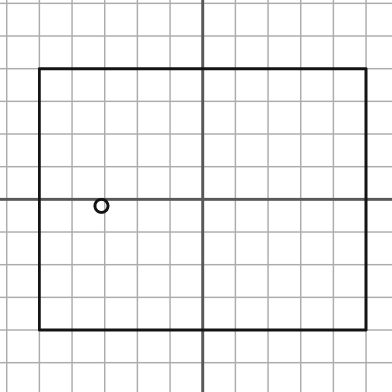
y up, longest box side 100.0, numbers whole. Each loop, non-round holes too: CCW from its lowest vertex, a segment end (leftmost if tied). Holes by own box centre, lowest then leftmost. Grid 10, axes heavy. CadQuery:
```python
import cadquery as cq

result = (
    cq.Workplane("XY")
    .moveTo(-50.0, -40.0)
    .lineTo(50.0, -40.0)
    .lineTo(50.0, 40.0)
    .lineTo(-50.0, 40.0)
    .close()
    .moveTo(-31.0, -2.0)
    .circle(2.0)
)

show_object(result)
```